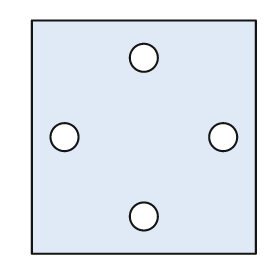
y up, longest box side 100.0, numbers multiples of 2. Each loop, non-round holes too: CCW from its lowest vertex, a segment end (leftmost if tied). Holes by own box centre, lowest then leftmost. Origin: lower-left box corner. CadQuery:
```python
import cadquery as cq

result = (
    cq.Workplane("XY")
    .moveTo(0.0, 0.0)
    .lineTo(96.0, 0.0)
    .lineTo(96.0, 100.0)
    .lineTo(0.0, 100.0)
    .close()
    .moveTo(48.0, 16.0)
    .circle(6.0)
    .moveTo(14.0, 50.0)
    .circle(6.0)
    .moveTo(82.0, 50.0)
    .circle(6.0)
    .moveTo(48.0, 84.0)
    .circle(6.0)
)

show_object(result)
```